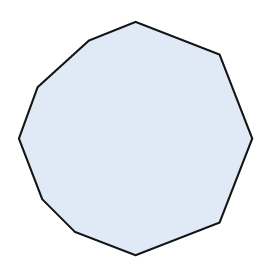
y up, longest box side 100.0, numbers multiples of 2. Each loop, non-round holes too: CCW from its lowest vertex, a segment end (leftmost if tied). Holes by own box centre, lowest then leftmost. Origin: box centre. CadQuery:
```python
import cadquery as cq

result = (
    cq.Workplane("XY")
    .moveTo(0.0, -50.0)
    .lineTo(36.0, -36.0)
    .lineTo(50.0, 0.0)
    .lineTo(36.0, 36.0)
    .lineTo(0.0, 50.0)
    .lineTo(-20.0, 42.0)
    .lineTo(-42.0, 22.0)
    .lineTo(-50.0, 0.0)
    .lineTo(-40.0, -26.0)
    .lineTo(-26.0, -40.0)
    .close()
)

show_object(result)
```